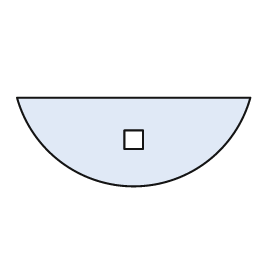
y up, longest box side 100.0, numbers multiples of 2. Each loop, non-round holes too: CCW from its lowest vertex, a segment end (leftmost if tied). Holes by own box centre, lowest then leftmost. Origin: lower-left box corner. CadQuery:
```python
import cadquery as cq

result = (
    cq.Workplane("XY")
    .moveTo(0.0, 38.0)
    .threePointArc((50.0, 0.0), (100.0, 38.0))
    .close()
    .moveTo(46.0, 16.0)
    .lineTo(54.0, 16.0)
    .lineTo(54.0, 24.0)
    .lineTo(46.0, 24.0)
    .close()
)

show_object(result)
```